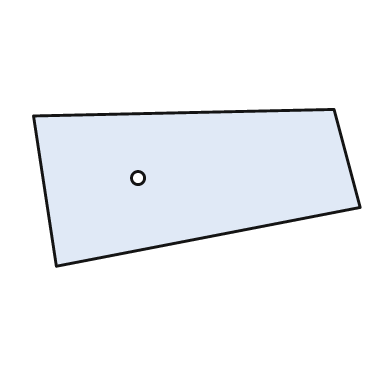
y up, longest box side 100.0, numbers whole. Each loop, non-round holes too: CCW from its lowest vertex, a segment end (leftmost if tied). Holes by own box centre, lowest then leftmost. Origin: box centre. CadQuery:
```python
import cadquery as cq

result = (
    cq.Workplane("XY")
    .moveTo(-43.0, -24.0)
    .lineTo(50.0, -6.0)
    .lineTo(42.0, 24.0)
    .lineTo(-50.0, 22.0)
    .close()
    .moveTo(-18.0, 3.0)
    .circle(2.0)
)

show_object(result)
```